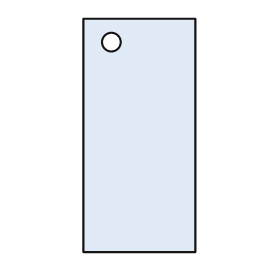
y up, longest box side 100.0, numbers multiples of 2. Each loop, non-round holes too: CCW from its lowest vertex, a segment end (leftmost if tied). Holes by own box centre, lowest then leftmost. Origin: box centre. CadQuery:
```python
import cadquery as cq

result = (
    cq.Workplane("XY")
    .moveTo(-24.0, -50.0)
    .lineTo(24.0, -50.0)
    .lineTo(24.0, 50.0)
    .lineTo(-24.0, 50.0)
    .close()
    .moveTo(-12.0, 40.0)
    .circle(4.0)
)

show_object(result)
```